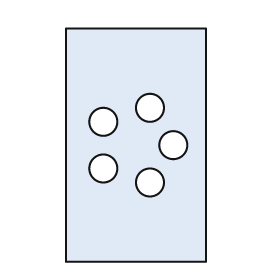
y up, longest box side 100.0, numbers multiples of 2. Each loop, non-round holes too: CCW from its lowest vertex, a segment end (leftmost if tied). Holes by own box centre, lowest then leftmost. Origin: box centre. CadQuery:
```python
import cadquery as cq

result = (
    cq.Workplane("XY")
    .moveTo(-30.0, -50.0)
    .lineTo(30.0, -50.0)
    .lineTo(30.0, 50.0)
    .lineTo(-30.0, 50.0)
    .close()
    .moveTo(6.0, -16.0)
    .circle(6.0)
    .moveTo(-14.0, -10.0)
    .circle(6.0)
    .moveTo(16.0, 0.0)
    .circle(6.0)
    .moveTo(-14.0, 10.0)
    .circle(6.0)
    .moveTo(6.0, 16.0)
    .circle(6.0)
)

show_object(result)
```